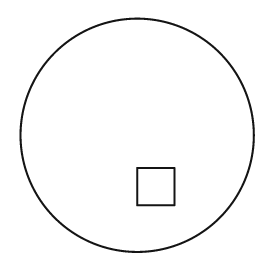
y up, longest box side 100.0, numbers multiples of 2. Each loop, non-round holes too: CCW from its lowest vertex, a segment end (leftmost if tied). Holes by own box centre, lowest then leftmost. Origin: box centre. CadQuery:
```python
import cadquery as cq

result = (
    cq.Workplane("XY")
    .moveTo(0.0, 0.0)
    .circle(50.0)
    .moveTo(0.0, -30.0)
    .lineTo(16.0, -30.0)
    .lineTo(16.0, -14.0)
    .lineTo(0.0, -14.0)
    .close()
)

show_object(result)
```